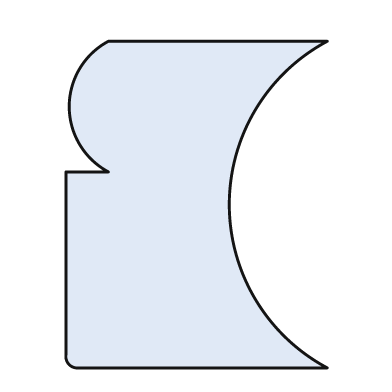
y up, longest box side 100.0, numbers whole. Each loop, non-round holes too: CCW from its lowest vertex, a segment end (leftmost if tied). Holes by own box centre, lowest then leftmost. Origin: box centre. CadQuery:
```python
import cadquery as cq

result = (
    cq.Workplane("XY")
    .moveTo(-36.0, -50.0)
    .lineTo(40.0, -50.0)
    .threePointArc((10.0, 0.0), (40.0, 50.0))
    .lineTo(-27.0, 50.0)
    .threePointArc((-39.0, 30.0), (-27.0, 10.0))
    .lineTo(-40.0, 10.0)
    .lineTo(-40.0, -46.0)
    .threePointArc((-39.0, -49.0), (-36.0, -50.0))
    .close()
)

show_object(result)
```